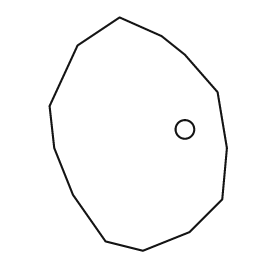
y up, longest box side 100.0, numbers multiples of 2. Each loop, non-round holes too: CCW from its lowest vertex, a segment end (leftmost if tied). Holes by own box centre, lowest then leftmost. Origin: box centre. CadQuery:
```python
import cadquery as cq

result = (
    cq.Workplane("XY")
    .moveTo(2.0, -50.0)
    .lineTo(22.0, -42.0)
    .lineTo(36.0, -28.0)
    .lineTo(38.0, -6.0)
    .lineTo(34.0, 18.0)
    .lineTo(20.0, 34.0)
    .lineTo(10.0, 42.0)
    .lineTo(-8.0, 50.0)
    .lineTo(-26.0, 38.0)
    .lineTo(-38.0, 12.0)
    .lineTo(-36.0, -6.0)
    .lineTo(-28.0, -26.0)
    .lineTo(-14.0, -46.0)
    .close()
    .moveTo(20.0, 2.0)
    .circle(4.0)
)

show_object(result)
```